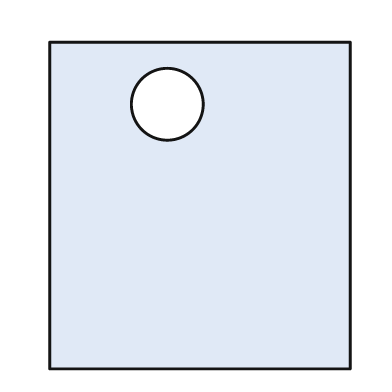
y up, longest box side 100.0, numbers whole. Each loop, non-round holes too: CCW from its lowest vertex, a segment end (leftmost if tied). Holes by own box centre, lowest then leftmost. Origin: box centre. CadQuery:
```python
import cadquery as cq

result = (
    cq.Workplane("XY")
    .moveTo(-46.0, -50.0)
    .lineTo(46.0, -50.0)
    .lineTo(46.0, 50.0)
    .lineTo(-46.0, 50.0)
    .close()
    .moveTo(-10.0, 31.0)
    .circle(11.0)
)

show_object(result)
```